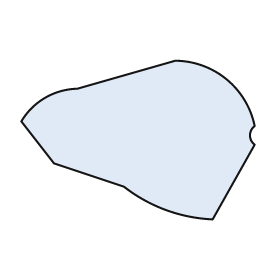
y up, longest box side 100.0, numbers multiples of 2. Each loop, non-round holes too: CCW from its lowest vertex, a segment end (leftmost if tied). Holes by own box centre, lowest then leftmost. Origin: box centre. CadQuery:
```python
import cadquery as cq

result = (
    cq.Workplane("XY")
    .moveTo(32.0, -34.0)
    .lineTo(50.0, -2.0)
    .threePointArc((48.0, 2.0), (50.0, 6.0))
    .threePointArc((38.0, 26.0), (16.0, 34.0))
    .lineTo(-26.0, 22.0)
    .threePointArc((-40.0, 18.0), (-50.0, 8.0))
    .lineTo(-36.0, -10.0)
    .lineTo(-6.0, -20.0)
    .threePointArc((12.0, -30.0), (32.0, -34.0))
    .close()
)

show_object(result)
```